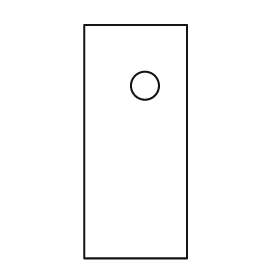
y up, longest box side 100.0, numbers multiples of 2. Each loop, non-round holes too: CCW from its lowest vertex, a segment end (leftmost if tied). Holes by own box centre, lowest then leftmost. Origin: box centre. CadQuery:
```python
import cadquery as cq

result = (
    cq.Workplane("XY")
    .moveTo(-22.0, -50.0)
    .lineTo(22.0, -50.0)
    .lineTo(22.0, 50.0)
    .lineTo(-22.0, 50.0)
    .close()
    .moveTo(4.0, 24.0)
    .circle(6.0)
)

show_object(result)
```